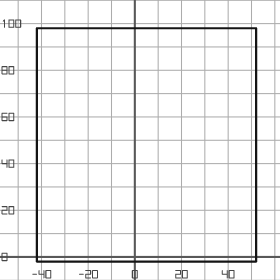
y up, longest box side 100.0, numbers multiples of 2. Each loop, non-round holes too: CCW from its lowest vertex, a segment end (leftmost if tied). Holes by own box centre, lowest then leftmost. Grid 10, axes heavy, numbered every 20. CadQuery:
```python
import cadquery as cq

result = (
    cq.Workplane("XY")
    .moveTo(-42.0, -2.0)
    .lineTo(52.0, -2.0)
    .lineTo(52.0, 98.0)
    .lineTo(-42.0, 98.0)
    .close()
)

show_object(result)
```